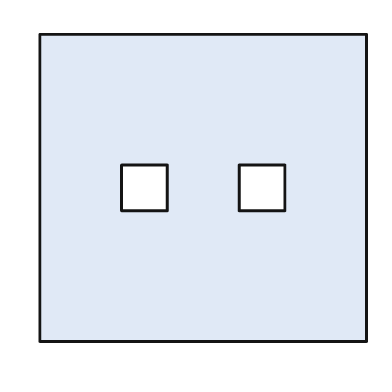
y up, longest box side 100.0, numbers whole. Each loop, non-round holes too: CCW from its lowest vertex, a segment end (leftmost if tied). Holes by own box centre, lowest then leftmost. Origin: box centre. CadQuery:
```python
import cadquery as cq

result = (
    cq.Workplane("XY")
    .moveTo(-50.0, -47.0)
    .lineTo(50.0, -47.0)
    .lineTo(50.0, 47.0)
    .lineTo(-50.0, 47.0)
    .close()
    .moveTo(-25.0, -7.0)
    .lineTo(-11.0, -7.0)
    .lineTo(-11.0, 7.0)
    .lineTo(-25.0, 7.0)
    .close()
    .moveTo(11.0, -7.0)
    .lineTo(25.0, -7.0)
    .lineTo(25.0, 7.0)
    .lineTo(11.0, 7.0)
    .close()
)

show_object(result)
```